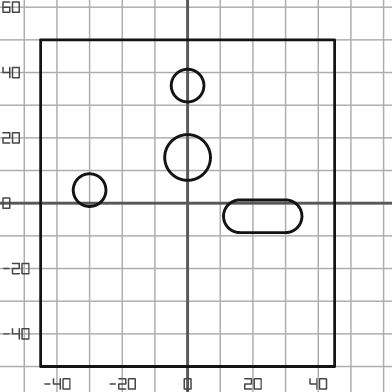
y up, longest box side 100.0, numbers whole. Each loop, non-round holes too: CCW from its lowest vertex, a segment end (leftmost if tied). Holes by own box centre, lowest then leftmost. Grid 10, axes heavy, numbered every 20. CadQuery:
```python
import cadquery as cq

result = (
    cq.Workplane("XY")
    .moveTo(-45.0, -50.0)
    .lineTo(45.0, -50.0)
    .lineTo(45.0, 50.0)
    .lineTo(-45.0, 50.0)
    .close()
    .moveTo(16.0, -9.0)
    .lineTo(30.0, -9.0)
    .threePointArc((35.0, -4.0), (30.0, 1.0))
    .lineTo(16.0, 1.0)
    .threePointArc((11.0, -4.0), (16.0, -9.0))
    .close()
    .moveTo(-30.0, 4.0)
    .circle(5.0)
    .moveTo(0.0, 14.0)
    .circle(7.0)
    .moveTo(0.0, 36.0)
    .circle(5.0)
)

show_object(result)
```